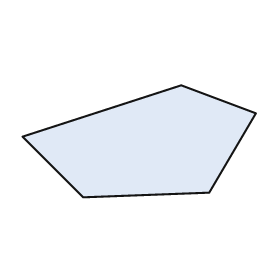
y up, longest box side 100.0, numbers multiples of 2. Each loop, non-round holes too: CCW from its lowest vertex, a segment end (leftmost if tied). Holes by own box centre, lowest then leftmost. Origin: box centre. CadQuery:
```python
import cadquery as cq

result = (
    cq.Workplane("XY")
    .moveTo(-24.0, -24.0)
    .lineTo(30.0, -22.0)
    .lineTo(50.0, 12.0)
    .lineTo(18.0, 24.0)
    .lineTo(-50.0, 2.0)
    .close()
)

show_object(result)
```